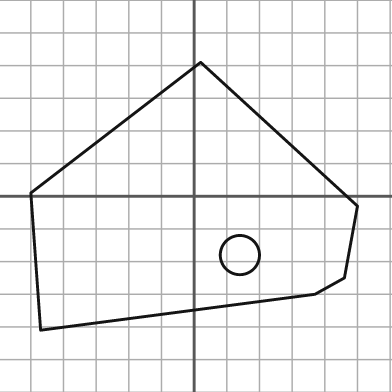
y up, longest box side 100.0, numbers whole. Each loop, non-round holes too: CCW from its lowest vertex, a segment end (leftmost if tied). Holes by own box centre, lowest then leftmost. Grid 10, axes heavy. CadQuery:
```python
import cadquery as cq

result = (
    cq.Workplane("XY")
    .moveTo(-47.0, -41.0)
    .lineTo(37.0, -30.0)
    .lineTo(46.0, -25.0)
    .lineTo(50.0, -3.0)
    .lineTo(2.0, 41.0)
    .lineTo(-50.0, 1.0)
    .close()
    .moveTo(14.0, -18.0)
    .circle(6.0)
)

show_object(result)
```